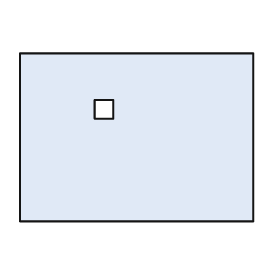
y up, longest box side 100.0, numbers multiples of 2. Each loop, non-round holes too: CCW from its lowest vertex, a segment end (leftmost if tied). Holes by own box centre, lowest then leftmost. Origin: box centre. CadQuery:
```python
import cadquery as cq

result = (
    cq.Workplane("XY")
    .moveTo(-50.0, -36.0)
    .lineTo(50.0, -36.0)
    .lineTo(50.0, 36.0)
    .lineTo(-50.0, 36.0)
    .close()
    .moveTo(-18.0, 8.0)
    .lineTo(-10.0, 8.0)
    .lineTo(-10.0, 16.0)
    .lineTo(-18.0, 16.0)
    .close()
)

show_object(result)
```